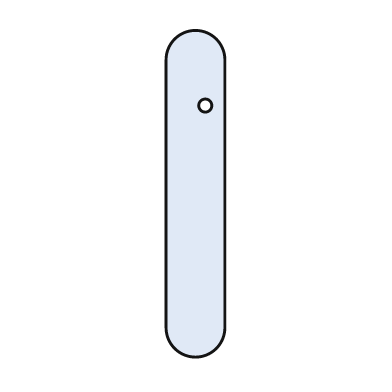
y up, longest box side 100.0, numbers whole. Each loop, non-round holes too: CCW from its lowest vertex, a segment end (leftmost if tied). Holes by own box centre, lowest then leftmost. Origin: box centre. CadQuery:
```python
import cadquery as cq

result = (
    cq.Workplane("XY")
    .moveTo(-9.0, -41.0)
    .threePointArc((0.0, -50.0), (9.0, -41.0))
    .lineTo(9.0, 41.0)
    .threePointArc((0.0, 50.0), (-9.0, 41.0))
    .close()
    .moveTo(3.0, 27.0)
    .circle(2.0)
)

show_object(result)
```